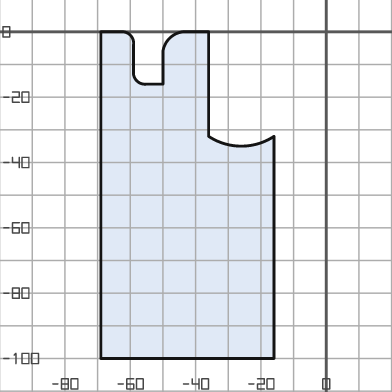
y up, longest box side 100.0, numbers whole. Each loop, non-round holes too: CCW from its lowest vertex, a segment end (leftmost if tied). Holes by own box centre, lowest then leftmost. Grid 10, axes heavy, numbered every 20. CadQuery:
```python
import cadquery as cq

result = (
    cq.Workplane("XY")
    .moveTo(-69.0, -100.0)
    .lineTo(-16.0, -100.0)
    .lineTo(-16.0, -32.0)
    .threePointArc((-26.0, -35.0), (-36.0, -32.0))
    .lineTo(-36.0, 0.0)
    .lineTo(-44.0, 0.0)
    .threePointArc((-48.0, -2.0), (-50.0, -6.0))
    .lineTo(-50.0, -16.0)
    .lineTo(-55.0, -16.0)
    .threePointArc((-58.0, -15.0), (-59.0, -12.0))
    .lineTo(-59.0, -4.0)
    .threePointArc((-60.0, -1.0), (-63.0, 0.0))
    .lineTo(-69.0, 0.0)
    .close()
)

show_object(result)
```